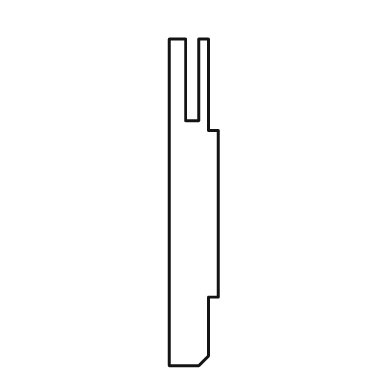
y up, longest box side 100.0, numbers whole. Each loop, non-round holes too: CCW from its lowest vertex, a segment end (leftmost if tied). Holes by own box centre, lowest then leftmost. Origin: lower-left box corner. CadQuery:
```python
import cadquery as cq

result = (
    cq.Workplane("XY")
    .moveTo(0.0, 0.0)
    .lineTo(9.0, 0.0)
    .lineTo(12.0, 3.0)
    .lineTo(12.0, 21.0)
    .lineTo(15.0, 21.0)
    .lineTo(15.0, 72.0)
    .lineTo(12.0, 72.0)
    .lineTo(12.0, 100.0)
    .lineTo(9.0, 100.0)
    .lineTo(9.0, 75.0)
    .lineTo(5.0, 75.0)
    .lineTo(5.0, 100.0)
    .lineTo(0.0, 100.0)
    .close()
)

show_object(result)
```